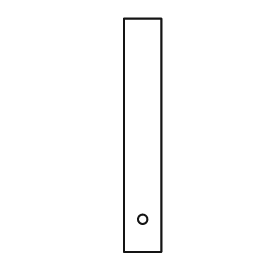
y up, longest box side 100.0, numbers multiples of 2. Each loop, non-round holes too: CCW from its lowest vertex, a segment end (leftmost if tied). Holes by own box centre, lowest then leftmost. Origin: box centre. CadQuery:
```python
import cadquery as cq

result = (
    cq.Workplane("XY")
    .moveTo(-8.0, -50.0)
    .lineTo(8.0, -50.0)
    .lineTo(8.0, 50.0)
    .lineTo(-8.0, 50.0)
    .close()
    .moveTo(0.0, -36.0)
    .circle(2.0)
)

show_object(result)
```